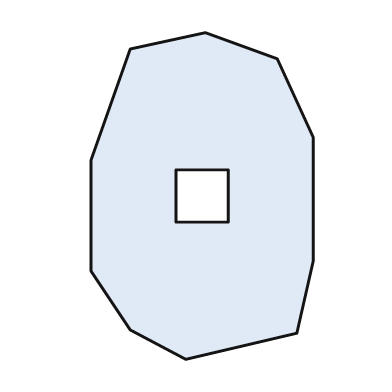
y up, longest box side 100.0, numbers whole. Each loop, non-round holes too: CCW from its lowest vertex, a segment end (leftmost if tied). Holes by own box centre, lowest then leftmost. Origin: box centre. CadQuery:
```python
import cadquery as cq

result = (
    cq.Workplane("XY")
    .moveTo(-5.0, -50.0)
    .lineTo(29.0, -42.0)
    .lineTo(34.0, -20.0)
    .lineTo(34.0, 18.0)
    .lineTo(23.0, 42.0)
    .lineTo(1.0, 50.0)
    .lineTo(-22.0, 45.0)
    .lineTo(-34.0, 11.0)
    .lineTo(-34.0, -23.0)
    .lineTo(-22.0, -41.0)
    .close()
    .moveTo(-8.0, -8.0)
    .lineTo(8.0, -8.0)
    .lineTo(8.0, 8.0)
    .lineTo(-8.0, 8.0)
    .close()
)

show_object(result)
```